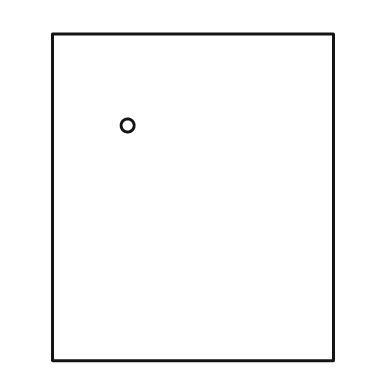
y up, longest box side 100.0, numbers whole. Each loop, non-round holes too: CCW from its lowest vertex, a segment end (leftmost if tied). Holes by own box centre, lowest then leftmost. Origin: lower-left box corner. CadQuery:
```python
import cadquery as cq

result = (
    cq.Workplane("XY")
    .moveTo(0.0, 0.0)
    .lineTo(86.0, 0.0)
    .lineTo(86.0, 100.0)
    .lineTo(0.0, 100.0)
    .close()
    .moveTo(23.0, 72.0)
    .circle(2.0)
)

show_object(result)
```